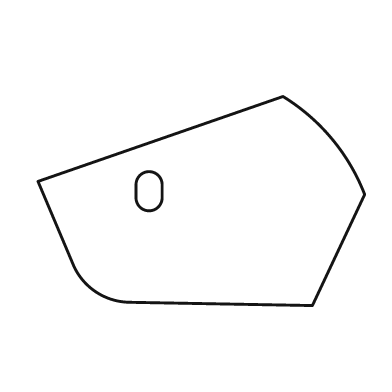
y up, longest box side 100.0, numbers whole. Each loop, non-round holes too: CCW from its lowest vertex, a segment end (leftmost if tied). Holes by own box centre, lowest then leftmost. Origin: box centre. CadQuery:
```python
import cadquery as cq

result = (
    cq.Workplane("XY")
    .moveTo(34.0, -32.0)
    .lineTo(50.0, 2.0)
    .threePointArc((40.0, 19.0), (25.0, 32.0))
    .lineTo(-50.0, 6.0)
    .lineTo(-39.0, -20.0)
    .threePointArc((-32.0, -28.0), (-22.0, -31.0))
    .close()
    .moveTo(-20.0, 1.0)
    .threePointArc((-16.0, -3.0), (-12.0, 1.0))
    .lineTo(-12.0, 5.0)
    .threePointArc((-16.0, 9.0), (-20.0, 5.0))
    .close()
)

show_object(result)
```